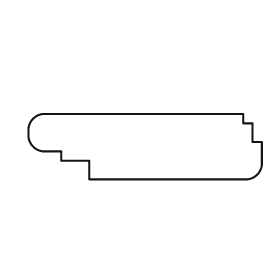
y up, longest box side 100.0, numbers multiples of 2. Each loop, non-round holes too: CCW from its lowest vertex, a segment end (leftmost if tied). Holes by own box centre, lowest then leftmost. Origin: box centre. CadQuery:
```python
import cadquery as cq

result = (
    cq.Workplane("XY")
    .moveTo(-24.0, -14.0)
    .lineTo(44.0, -14.0)
    .threePointArc((48.0, -12.0), (50.0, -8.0))
    .lineTo(50.0, 2.0)
    .lineTo(46.0, 2.0)
    .lineTo(46.0, 10.0)
    .lineTo(42.0, 10.0)
    .lineTo(42.0, 14.0)
    .lineTo(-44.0, 14.0)
    .threePointArc((-48.0, 12.0), (-50.0, 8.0))
    .lineTo(-50.0, 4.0)
    .threePointArc((-48.0, 0.0), (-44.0, -2.0))
    .lineTo(-36.0, -2.0)
    .lineTo(-36.0, -6.0)
    .lineTo(-24.0, -6.0)
    .close()
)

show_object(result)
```